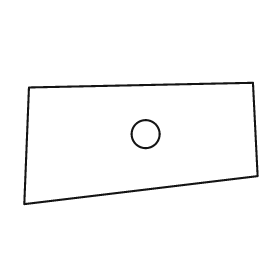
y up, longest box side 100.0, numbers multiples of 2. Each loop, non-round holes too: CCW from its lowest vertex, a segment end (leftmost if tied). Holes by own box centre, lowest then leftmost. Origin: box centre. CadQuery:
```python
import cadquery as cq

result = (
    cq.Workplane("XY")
    .moveTo(-50.0, -26.0)
    .lineTo(50.0, -14.0)
    .lineTo(48.0, 26.0)
    .lineTo(-48.0, 24.0)
    .close()
    .moveTo(2.0, 4.0)
    .circle(6.0)
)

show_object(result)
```